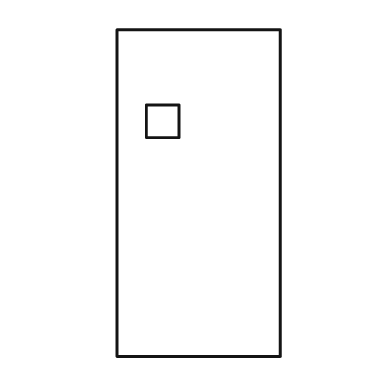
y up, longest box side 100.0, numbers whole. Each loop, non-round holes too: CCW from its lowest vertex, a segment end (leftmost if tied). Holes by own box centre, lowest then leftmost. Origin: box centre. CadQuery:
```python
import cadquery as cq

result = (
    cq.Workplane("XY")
    .moveTo(-25.0, -50.0)
    .lineTo(25.0, -50.0)
    .lineTo(25.0, 50.0)
    .lineTo(-25.0, 50.0)
    .close()
    .moveTo(-16.0, 17.0)
    .lineTo(-6.0, 17.0)
    .lineTo(-6.0, 27.0)
    .lineTo(-16.0, 27.0)
    .close()
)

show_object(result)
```